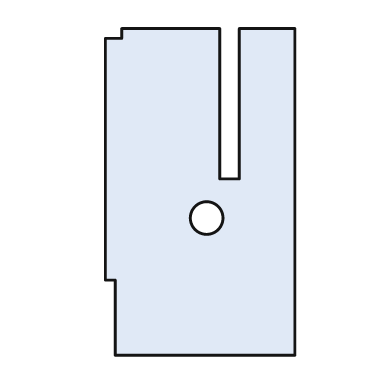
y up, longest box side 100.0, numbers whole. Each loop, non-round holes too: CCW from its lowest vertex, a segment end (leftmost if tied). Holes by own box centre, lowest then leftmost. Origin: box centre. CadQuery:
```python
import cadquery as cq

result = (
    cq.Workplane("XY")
    .moveTo(-26.0, -50.0)
    .lineTo(29.0, -50.0)
    .lineTo(29.0, 50.0)
    .lineTo(12.0, 50.0)
    .lineTo(12.0, 4.0)
    .lineTo(6.0, 4.0)
    .lineTo(6.0, 50.0)
    .lineTo(-24.0, 50.0)
    .lineTo(-24.0, 47.0)
    .lineTo(-29.0, 47.0)
    .lineTo(-29.0, -27.0)
    .lineTo(-26.0, -27.0)
    .close()
    .moveTo(2.0, -8.0)
    .circle(5.0)
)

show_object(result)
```